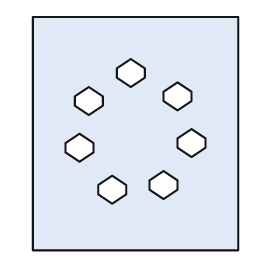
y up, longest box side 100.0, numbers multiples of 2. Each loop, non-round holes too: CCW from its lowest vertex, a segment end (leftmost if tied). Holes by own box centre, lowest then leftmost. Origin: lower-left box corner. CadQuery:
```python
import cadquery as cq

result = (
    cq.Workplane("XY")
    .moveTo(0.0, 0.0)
    .lineTo(88.0, 0.0)
    .lineTo(88.0, 100.0)
    .lineTo(0.0, 100.0)
    .close()
    .moveTo(34.0, 20.0)
    .lineTo(40.0, 24.0)
    .lineTo(40.0, 28.0)
    .lineTo(34.0, 32.0)
    .lineTo(28.0, 28.0)
    .lineTo(28.0, 24.0)
    .close()
    .moveTo(56.0, 22.0)
    .lineTo(62.0, 26.0)
    .lineTo(62.0, 30.0)
    .lineTo(56.0, 34.0)
    .lineTo(50.0, 30.0)
    .lineTo(50.0, 26.0)
    .close()
    .moveTo(20.0, 38.0)
    .lineTo(26.0, 42.0)
    .lineTo(26.0, 46.0)
    .lineTo(20.0, 50.0)
    .lineTo(14.0, 46.0)
    .lineTo(14.0, 42.0)
    .close()
    .moveTo(68.0, 40.0)
    .lineTo(74.0, 44.0)
    .lineTo(74.0, 48.0)
    .lineTo(68.0, 52.0)
    .lineTo(62.0, 48.0)
    .lineTo(62.0, 44.0)
    .close()
    .moveTo(24.0, 58.0)
    .lineTo(30.0, 62.0)
    .lineTo(30.0, 66.0)
    .lineTo(24.0, 70.0)
    .lineTo(18.0, 66.0)
    .lineTo(18.0, 62.0)
    .close()
    .moveTo(62.0, 60.0)
    .lineTo(68.0, 64.0)
    .lineTo(68.0, 68.0)
    .lineTo(62.0, 72.0)
    .lineTo(56.0, 68.0)
    .lineTo(56.0, 64.0)
    .close()
    .moveTo(42.0, 70.0)
    .lineTo(48.0, 74.0)
    .lineTo(48.0, 78.0)
    .lineTo(42.0, 82.0)
    .lineTo(36.0, 78.0)
    .lineTo(36.0, 74.0)
    .close()
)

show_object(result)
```